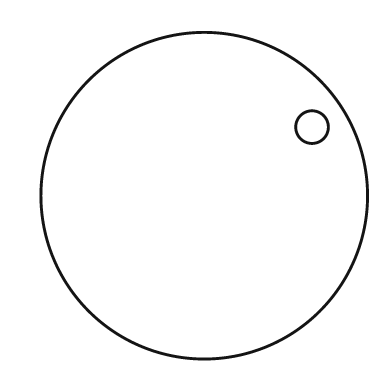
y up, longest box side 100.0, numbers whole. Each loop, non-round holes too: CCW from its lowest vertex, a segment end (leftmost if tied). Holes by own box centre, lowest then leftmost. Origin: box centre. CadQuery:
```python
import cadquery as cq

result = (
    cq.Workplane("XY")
    .moveTo(0.0, 0.0)
    .circle(50.0)
    .moveTo(33.0, 21.0)
    .circle(5.0)
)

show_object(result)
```